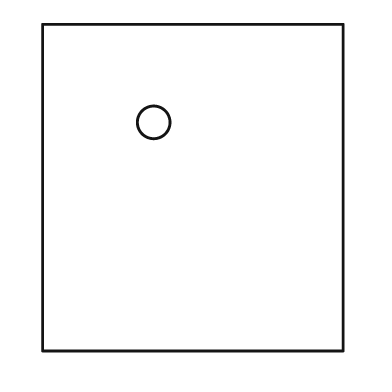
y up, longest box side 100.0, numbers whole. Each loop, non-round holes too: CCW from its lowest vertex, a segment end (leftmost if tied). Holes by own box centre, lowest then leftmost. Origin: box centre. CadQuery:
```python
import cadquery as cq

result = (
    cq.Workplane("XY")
    .moveTo(-46.0, -50.0)
    .lineTo(46.0, -50.0)
    .lineTo(46.0, 50.0)
    .lineTo(-46.0, 50.0)
    .close()
    .moveTo(-12.0, 20.0)
    .circle(5.0)
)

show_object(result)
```